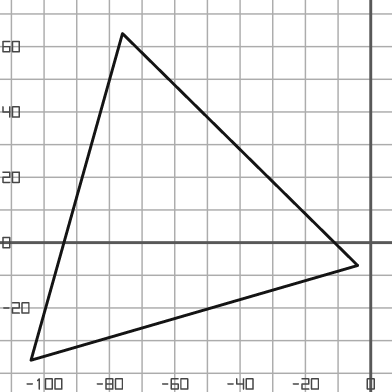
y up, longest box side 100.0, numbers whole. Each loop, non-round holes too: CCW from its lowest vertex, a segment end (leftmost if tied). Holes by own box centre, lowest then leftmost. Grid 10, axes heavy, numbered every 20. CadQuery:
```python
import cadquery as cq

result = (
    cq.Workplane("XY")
    .moveTo(-104.0, -36.0)
    .lineTo(-4.0, -7.0)
    .lineTo(-76.0, 64.0)
    .close()
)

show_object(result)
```